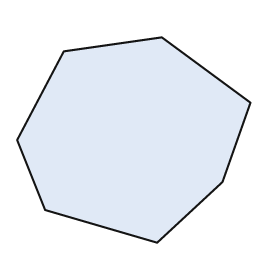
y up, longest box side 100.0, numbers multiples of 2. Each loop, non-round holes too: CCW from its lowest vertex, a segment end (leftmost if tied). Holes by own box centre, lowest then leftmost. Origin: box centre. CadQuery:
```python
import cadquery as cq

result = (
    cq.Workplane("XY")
    .moveTo(10.0, -44.0)
    .lineTo(38.0, -18.0)
    .lineTo(50.0, 16.0)
    .lineTo(12.0, 44.0)
    .lineTo(-30.0, 38.0)
    .lineTo(-50.0, 0.0)
    .lineTo(-38.0, -30.0)
    .close()
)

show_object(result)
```